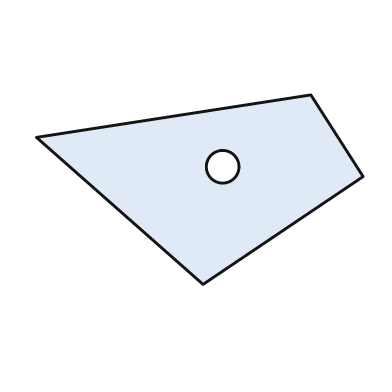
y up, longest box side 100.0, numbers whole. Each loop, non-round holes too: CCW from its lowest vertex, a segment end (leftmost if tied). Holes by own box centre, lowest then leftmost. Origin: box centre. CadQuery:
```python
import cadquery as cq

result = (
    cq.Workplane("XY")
    .moveTo(1.0, -29.0)
    .lineTo(50.0, 4.0)
    .lineTo(34.0, 29.0)
    .lineTo(-50.0, 16.0)
    .close()
    .moveTo(7.0, 7.0)
    .circle(5.0)
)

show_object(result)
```